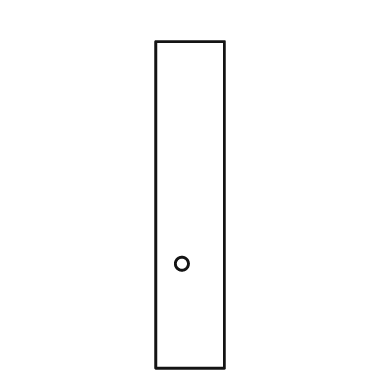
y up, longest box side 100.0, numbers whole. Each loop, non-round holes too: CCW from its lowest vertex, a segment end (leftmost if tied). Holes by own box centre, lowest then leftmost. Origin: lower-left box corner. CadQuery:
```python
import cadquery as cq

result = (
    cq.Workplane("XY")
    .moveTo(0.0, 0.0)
    .lineTo(21.0, 0.0)
    .lineTo(21.0, 100.0)
    .lineTo(0.0, 100.0)
    .close()
    .moveTo(8.0, 32.0)
    .circle(2.0)
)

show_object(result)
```